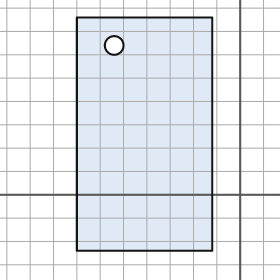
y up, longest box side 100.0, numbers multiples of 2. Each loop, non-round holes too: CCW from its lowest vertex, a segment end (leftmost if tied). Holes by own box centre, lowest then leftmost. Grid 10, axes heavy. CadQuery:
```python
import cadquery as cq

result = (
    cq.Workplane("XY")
    .moveTo(-70.0, -24.0)
    .lineTo(-12.0, -24.0)
    .lineTo(-12.0, 76.0)
    .lineTo(-70.0, 76.0)
    .close()
    .moveTo(-54.0, 64.0)
    .circle(4.0)
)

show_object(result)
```